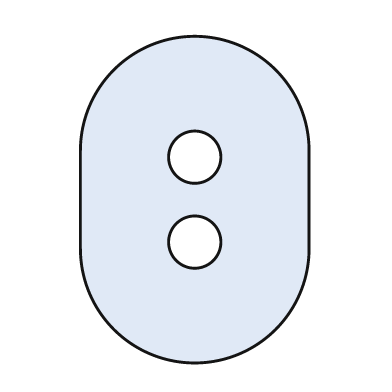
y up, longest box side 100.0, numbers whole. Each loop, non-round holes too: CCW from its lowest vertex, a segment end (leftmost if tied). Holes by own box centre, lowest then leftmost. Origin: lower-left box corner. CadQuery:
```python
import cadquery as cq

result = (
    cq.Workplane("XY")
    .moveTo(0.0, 35.0)
    .threePointArc((35.0, 0.0), (70.0, 35.0))
    .lineTo(70.0, 65.0)
    .threePointArc((35.0, 100.0), (0.0, 65.0))
    .close()
    .moveTo(35.0, 37.0)
    .circle(8.0)
    .moveTo(35.0, 63.0)
    .circle(8.0)
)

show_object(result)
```